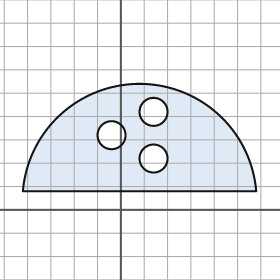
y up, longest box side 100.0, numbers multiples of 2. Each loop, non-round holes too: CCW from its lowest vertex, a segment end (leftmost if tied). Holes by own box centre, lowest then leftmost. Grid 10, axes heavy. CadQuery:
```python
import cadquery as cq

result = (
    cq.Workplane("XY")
    .moveTo(-42.0, 8.0)
    .lineTo(58.0, 8.0)
    .threePointArc((8.0, 54.0), (-42.0, 8.0))
    .close()
    .moveTo(14.0, 22.0)
    .circle(6.0)
    .moveTo(-4.0, 32.0)
    .circle(6.0)
    .moveTo(14.0, 42.0)
    .circle(6.0)
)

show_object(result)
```